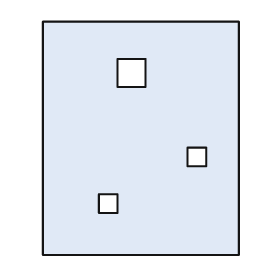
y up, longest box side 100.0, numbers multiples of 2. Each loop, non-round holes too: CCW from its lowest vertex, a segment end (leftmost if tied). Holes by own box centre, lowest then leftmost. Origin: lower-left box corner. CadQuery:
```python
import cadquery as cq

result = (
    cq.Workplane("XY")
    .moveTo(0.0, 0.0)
    .lineTo(84.0, 0.0)
    .lineTo(84.0, 100.0)
    .lineTo(0.0, 100.0)
    .close()
    .moveTo(24.0, 18.0)
    .lineTo(32.0, 18.0)
    .lineTo(32.0, 26.0)
    .lineTo(24.0, 26.0)
    .close()
    .moveTo(62.0, 38.0)
    .lineTo(70.0, 38.0)
    .lineTo(70.0, 46.0)
    .lineTo(62.0, 46.0)
    .close()
    .moveTo(32.0, 72.0)
    .lineTo(44.0, 72.0)
    .lineTo(44.0, 84.0)
    .lineTo(32.0, 84.0)
    .close()
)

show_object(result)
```